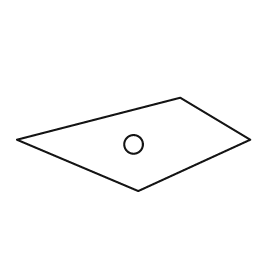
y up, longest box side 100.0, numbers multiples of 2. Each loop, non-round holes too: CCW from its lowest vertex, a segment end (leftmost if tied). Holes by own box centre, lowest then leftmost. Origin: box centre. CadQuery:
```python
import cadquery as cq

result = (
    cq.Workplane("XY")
    .moveTo(2.0, -20.0)
    .lineTo(50.0, 2.0)
    .lineTo(20.0, 20.0)
    .lineTo(-50.0, 2.0)
    .close()
    .moveTo(0.0, 0.0)
    .circle(4.0)
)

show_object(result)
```